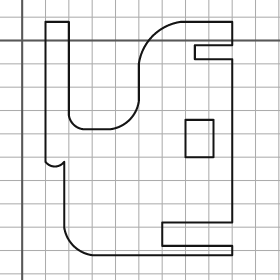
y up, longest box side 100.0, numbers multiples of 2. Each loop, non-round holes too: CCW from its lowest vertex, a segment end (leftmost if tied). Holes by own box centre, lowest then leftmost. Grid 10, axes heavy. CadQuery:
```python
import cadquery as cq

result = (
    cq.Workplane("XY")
    .moveTo(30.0, -92.0)
    .lineTo(90.0, -92.0)
    .lineTo(90.0, -88.0)
    .lineTo(60.0, -88.0)
    .lineTo(60.0, -78.0)
    .lineTo(90.0, -78.0)
    .lineTo(90.0, -8.0)
    .lineTo(74.0, -8.0)
    .lineTo(74.0, -2.0)
    .lineTo(90.0, -2.0)
    .lineTo(90.0, 8.0)
    .lineTo(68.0, 8.0)
    .threePointArc((56.0, 2.0), (50.0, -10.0))
    .lineTo(50.0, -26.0)
    .threePointArc((46.0, -34.0), (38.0, -38.0))
    .lineTo(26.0, -38.0)
    .threePointArc((22.0, -36.0), (20.0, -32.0))
    .lineTo(20.0, 8.0)
    .lineTo(10.0, 8.0)
    .lineTo(10.0, -52.0)
    .threePointArc((14.0, -54.0), (18.0, -52.0))
    .lineTo(18.0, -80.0)
    .threePointArc((22.0, -88.0), (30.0, -92.0))
    .close()
    .moveTo(70.0, -50.0)
    .lineTo(82.0, -50.0)
    .lineTo(82.0, -34.0)
    .lineTo(70.0, -34.0)
    .close()
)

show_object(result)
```